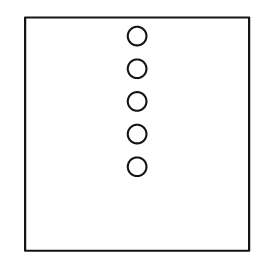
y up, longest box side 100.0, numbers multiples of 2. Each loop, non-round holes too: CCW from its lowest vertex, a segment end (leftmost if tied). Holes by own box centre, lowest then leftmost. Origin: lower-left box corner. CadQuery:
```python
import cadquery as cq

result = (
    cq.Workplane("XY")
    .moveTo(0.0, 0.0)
    .lineTo(96.0, 0.0)
    .lineTo(96.0, 100.0)
    .lineTo(0.0, 100.0)
    .close()
    .moveTo(48.0, 36.0)
    .circle(4.0)
    .moveTo(48.0, 50.0)
    .circle(4.0)
    .moveTo(48.0, 64.0)
    .circle(4.0)
    .moveTo(48.0, 78.0)
    .circle(4.0)
    .moveTo(48.0, 92.0)
    .circle(4.0)
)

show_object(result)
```